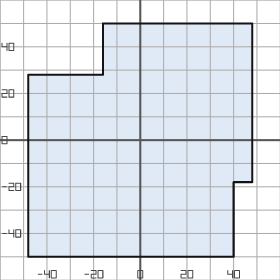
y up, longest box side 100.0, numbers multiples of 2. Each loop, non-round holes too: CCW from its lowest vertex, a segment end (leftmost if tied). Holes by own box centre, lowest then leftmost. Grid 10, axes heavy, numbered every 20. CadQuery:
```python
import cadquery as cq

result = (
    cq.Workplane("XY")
    .moveTo(-48.0, -50.0)
    .lineTo(40.0, -50.0)
    .lineTo(40.0, -18.0)
    .lineTo(48.0, -18.0)
    .lineTo(48.0, 50.0)
    .lineTo(-16.0, 50.0)
    .lineTo(-16.0, 28.0)
    .lineTo(-48.0, 28.0)
    .close()
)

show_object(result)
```